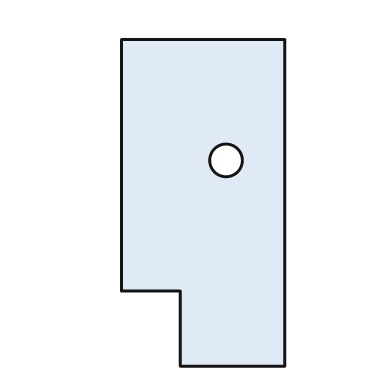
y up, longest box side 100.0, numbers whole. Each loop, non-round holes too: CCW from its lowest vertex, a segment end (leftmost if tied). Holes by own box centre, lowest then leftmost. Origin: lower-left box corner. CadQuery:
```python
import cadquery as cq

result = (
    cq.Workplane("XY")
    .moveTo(18.0, 0.0)
    .lineTo(50.0, 0.0)
    .lineTo(50.0, 100.0)
    .lineTo(0.0, 100.0)
    .lineTo(0.0, 23.0)
    .lineTo(18.0, 23.0)
    .close()
    .moveTo(32.0, 63.0)
    .circle(5.0)
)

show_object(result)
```